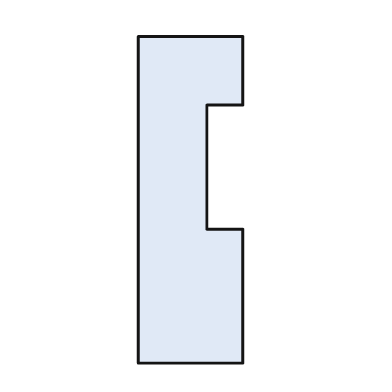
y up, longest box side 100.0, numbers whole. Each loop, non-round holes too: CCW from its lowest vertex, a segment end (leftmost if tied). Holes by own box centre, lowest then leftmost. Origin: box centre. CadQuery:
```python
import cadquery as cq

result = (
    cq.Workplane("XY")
    .moveTo(-16.0, -50.0)
    .lineTo(16.0, -50.0)
    .lineTo(16.0, -9.0)
    .lineTo(5.0, -9.0)
    .lineTo(5.0, 29.0)
    .lineTo(16.0, 29.0)
    .lineTo(16.0, 50.0)
    .lineTo(-16.0, 50.0)
    .close()
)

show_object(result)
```